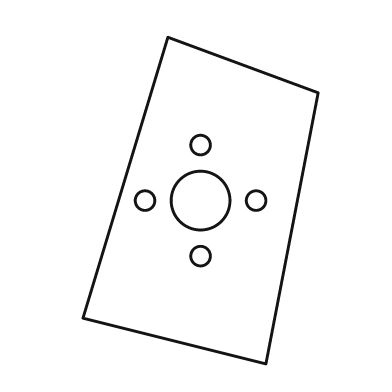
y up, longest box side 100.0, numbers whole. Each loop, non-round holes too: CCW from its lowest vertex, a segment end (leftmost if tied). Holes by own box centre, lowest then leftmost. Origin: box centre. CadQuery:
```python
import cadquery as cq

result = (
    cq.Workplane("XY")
    .moveTo(20.0, -50.0)
    .lineTo(36.0, 33.0)
    .lineTo(-10.0, 50.0)
    .lineTo(-36.0, -36.0)
    .close()
    .moveTo(0.0, -17.0)
    .circle(3.0)
    .moveTo(-17.0, 0.0)
    .circle(3.0)
    .moveTo(0.0, 0.0)
    .circle(9.0)
    .moveTo(17.0, 0.0)
    .circle(3.0)
    .moveTo(0.0, 17.0)
    .circle(3.0)
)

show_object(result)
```